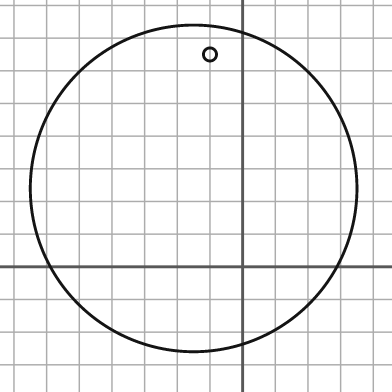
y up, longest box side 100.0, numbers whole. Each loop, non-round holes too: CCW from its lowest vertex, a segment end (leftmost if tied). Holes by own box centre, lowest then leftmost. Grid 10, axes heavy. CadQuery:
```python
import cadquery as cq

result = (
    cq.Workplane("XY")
    .moveTo(-15.0, 24.0)
    .circle(50.0)
    .moveTo(-10.0, 65.0)
    .circle(2.0)
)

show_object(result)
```